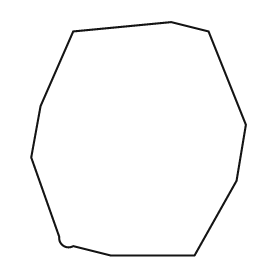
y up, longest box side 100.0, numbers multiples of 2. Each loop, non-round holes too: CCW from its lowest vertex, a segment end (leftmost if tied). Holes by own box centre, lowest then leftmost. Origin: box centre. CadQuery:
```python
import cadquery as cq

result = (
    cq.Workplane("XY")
    .moveTo(-12.0, -50.0)
    .lineTo(24.0, -50.0)
    .lineTo(42.0, -18.0)
    .lineTo(46.0, 6.0)
    .lineTo(30.0, 46.0)
    .lineTo(14.0, 50.0)
    .lineTo(-28.0, 46.0)
    .lineTo(-42.0, 14.0)
    .lineTo(-46.0, -8.0)
    .lineTo(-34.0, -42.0)
    .threePointArc((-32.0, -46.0), (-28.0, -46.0))
    .close()
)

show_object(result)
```